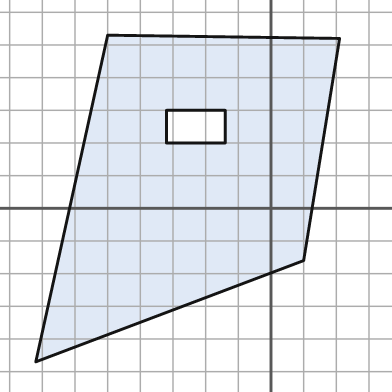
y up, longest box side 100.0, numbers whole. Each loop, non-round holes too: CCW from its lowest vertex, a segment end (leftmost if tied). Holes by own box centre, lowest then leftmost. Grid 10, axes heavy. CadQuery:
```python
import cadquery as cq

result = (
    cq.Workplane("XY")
    .moveTo(-72.0, -47.0)
    .lineTo(10.0, -16.0)
    .lineTo(21.0, 52.0)
    .lineTo(-50.0, 53.0)
    .close()
    .moveTo(-32.0, 20.0)
    .lineTo(-14.0, 20.0)
    .lineTo(-14.0, 30.0)
    .lineTo(-32.0, 30.0)
    .close()
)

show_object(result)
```